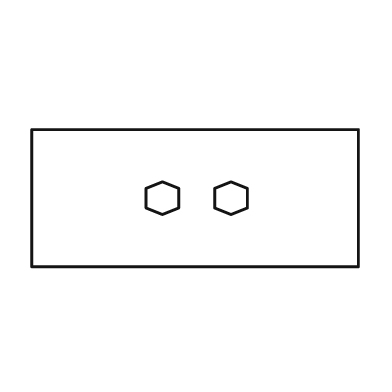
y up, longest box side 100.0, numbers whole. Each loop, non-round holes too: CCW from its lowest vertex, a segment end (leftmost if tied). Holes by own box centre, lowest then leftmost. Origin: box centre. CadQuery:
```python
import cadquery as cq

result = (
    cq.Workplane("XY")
    .moveTo(-50.0, -21.0)
    .lineTo(50.0, -21.0)
    .lineTo(50.0, 21.0)
    .lineTo(-50.0, 21.0)
    .close()
    .moveTo(-10.0, -5.0)
    .lineTo(-5.0, -3.0)
    .lineTo(-5.0, 3.0)
    .lineTo(-10.0, 5.0)
    .lineTo(-15.0, 3.0)
    .lineTo(-15.0, -3.0)
    .close()
    .moveTo(11.0, -5.0)
    .lineTo(16.0, -3.0)
    .lineTo(16.0, 3.0)
    .lineTo(11.0, 5.0)
    .lineTo(6.0, 3.0)
    .lineTo(6.0, -3.0)
    .close()
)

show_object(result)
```